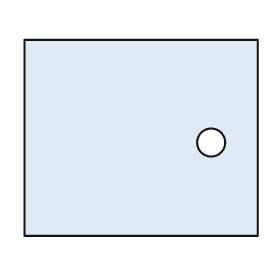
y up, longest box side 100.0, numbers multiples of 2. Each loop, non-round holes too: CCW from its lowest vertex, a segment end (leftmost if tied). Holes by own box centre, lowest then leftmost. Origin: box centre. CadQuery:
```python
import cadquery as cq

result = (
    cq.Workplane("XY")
    .moveTo(-50.0, -42.0)
    .lineTo(50.0, -42.0)
    .lineTo(50.0, 42.0)
    .lineTo(-50.0, 42.0)
    .close()
    .moveTo(30.0, -2.0)
    .circle(6.0)
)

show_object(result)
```